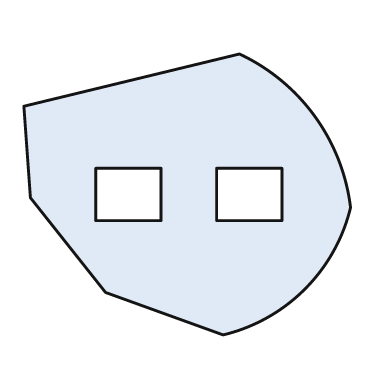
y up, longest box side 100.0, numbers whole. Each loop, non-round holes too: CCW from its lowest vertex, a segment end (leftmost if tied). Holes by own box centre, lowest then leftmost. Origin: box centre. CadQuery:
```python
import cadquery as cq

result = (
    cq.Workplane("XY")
    .moveTo(11.0, -43.0)
    .threePointArc((36.0, -29.0), (50.0, -4.0))
    .threePointArc((39.0, 24.0), (16.0, 43.0))
    .lineTo(-50.0, 27.0)
    .lineTo(-48.0, -1.0)
    .lineTo(-25.0, -30.0)
    .close()
    .moveTo(-28.0, -8.0)
    .lineTo(-8.0, -8.0)
    .lineTo(-8.0, 8.0)
    .lineTo(-28.0, 8.0)
    .close()
    .moveTo(9.0, -8.0)
    .lineTo(29.0, -8.0)
    .lineTo(29.0, 8.0)
    .lineTo(9.0, 8.0)
    .close()
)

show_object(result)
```